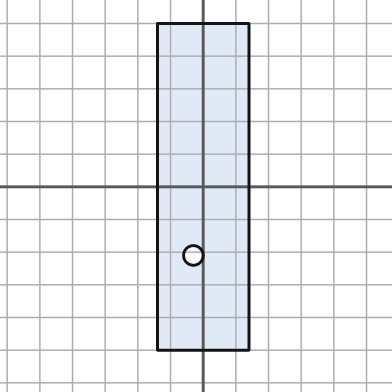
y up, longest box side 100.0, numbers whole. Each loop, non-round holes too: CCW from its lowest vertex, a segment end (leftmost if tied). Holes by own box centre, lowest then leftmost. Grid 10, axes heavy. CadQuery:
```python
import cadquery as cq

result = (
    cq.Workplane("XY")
    .moveTo(-14.0, -50.0)
    .lineTo(14.0, -50.0)
    .lineTo(14.0, 50.0)
    .lineTo(-14.0, 50.0)
    .close()
    .moveTo(-3.0, -21.0)
    .circle(3.0)
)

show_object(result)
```